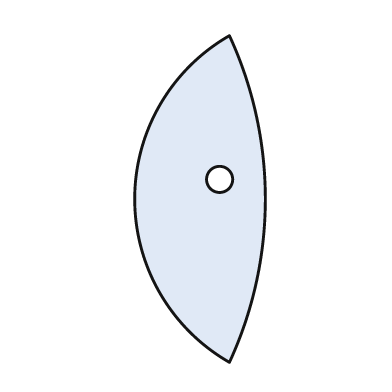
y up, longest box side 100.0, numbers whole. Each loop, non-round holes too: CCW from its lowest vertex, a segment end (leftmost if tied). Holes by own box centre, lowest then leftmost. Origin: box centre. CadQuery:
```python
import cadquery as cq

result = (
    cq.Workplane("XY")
    .moveTo(9.0, -50.0)
    .threePointArc((20.0, 0.0), (9.0, 50.0))
    .threePointArc((-20.0, 0.0), (9.0, -50.0))
    .close()
    .moveTo(6.0, 6.0)
    .circle(4.0)
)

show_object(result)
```